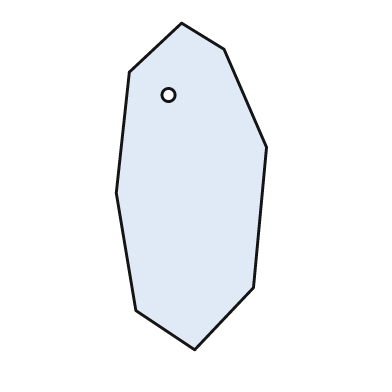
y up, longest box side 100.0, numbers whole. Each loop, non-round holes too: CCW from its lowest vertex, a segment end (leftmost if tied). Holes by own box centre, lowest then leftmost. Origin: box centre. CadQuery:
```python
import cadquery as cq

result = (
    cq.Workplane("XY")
    .moveTo(1.0, -50.0)
    .lineTo(19.0, -31.0)
    .lineTo(23.0, 12.0)
    .lineTo(10.0, 42.0)
    .lineTo(-3.0, 50.0)
    .lineTo(-19.0, 35.0)
    .lineTo(-23.0, -2.0)
    .lineTo(-17.0, -38.0)
    .close()
    .moveTo(-7.0, 28.0)
    .circle(2.0)
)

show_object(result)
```